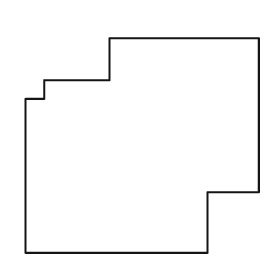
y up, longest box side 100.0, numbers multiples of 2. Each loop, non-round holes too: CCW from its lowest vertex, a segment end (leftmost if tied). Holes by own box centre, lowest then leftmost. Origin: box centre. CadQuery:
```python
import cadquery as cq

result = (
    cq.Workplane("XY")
    .moveTo(-50.0, -46.0)
    .lineTo(28.0, -46.0)
    .lineTo(28.0, -20.0)
    .lineTo(50.0, -20.0)
    .lineTo(50.0, 46.0)
    .lineTo(-14.0, 46.0)
    .lineTo(-14.0, 28.0)
    .lineTo(-42.0, 28.0)
    .lineTo(-42.0, 20.0)
    .lineTo(-50.0, 20.0)
    .close()
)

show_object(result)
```